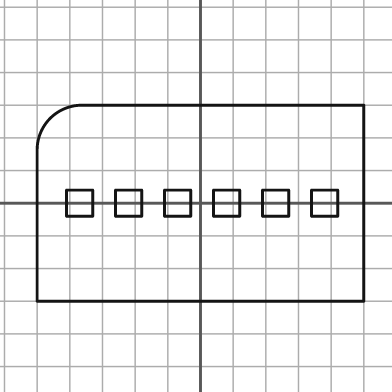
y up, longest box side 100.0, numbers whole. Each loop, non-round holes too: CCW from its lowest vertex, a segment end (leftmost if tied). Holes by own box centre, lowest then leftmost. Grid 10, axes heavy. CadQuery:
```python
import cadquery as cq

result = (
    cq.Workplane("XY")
    .moveTo(-50.0, -30.0)
    .lineTo(50.0, -30.0)
    .lineTo(50.0, 30.0)
    .lineTo(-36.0, 30.0)
    .threePointArc((-46.0, 26.0), (-50.0, 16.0))
    .close()
    .moveTo(-41.0, -4.0)
    .lineTo(-33.0, -4.0)
    .lineTo(-33.0, 4.0)
    .lineTo(-41.0, 4.0)
    .close()
    .moveTo(-26.0, -4.0)
    .lineTo(-18.0, -4.0)
    .lineTo(-18.0, 4.0)
    .lineTo(-26.0, 4.0)
    .close()
    .moveTo(-11.0, -4.0)
    .lineTo(-3.0, -4.0)
    .lineTo(-3.0, 4.0)
    .lineTo(-11.0, 4.0)
    .close()
    .moveTo(4.0, -4.0)
    .lineTo(12.0, -4.0)
    .lineTo(12.0, 4.0)
    .lineTo(4.0, 4.0)
    .close()
    .moveTo(19.0, -4.0)
    .lineTo(27.0, -4.0)
    .lineTo(27.0, 4.0)
    .lineTo(19.0, 4.0)
    .close()
    .moveTo(34.0, -4.0)
    .lineTo(42.0, -4.0)
    .lineTo(42.0, 4.0)
    .lineTo(34.0, 4.0)
    .close()
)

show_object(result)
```